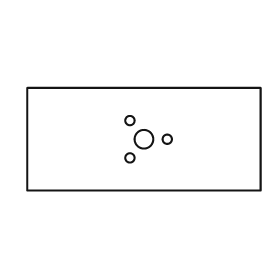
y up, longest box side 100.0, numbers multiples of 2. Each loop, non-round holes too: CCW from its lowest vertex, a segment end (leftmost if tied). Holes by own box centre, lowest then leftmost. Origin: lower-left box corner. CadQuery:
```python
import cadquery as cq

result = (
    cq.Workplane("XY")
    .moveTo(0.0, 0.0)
    .lineTo(100.0, 0.0)
    .lineTo(100.0, 44.0)
    .lineTo(0.0, 44.0)
    .close()
    .moveTo(44.0, 14.0)
    .circle(2.0)
    .moveTo(50.0, 22.0)
    .circle(4.0)
    .moveTo(60.0, 22.0)
    .circle(2.0)
    .moveTo(44.0, 30.0)
    .circle(2.0)
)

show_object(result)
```